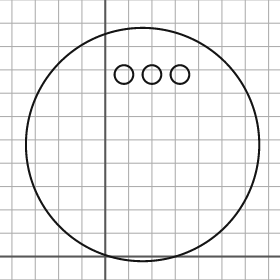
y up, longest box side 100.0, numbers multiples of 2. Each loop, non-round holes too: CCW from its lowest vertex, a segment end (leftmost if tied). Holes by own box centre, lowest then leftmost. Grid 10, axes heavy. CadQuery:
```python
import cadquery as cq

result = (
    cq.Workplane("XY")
    .moveTo(16.0, 48.0)
    .circle(50.0)
    .moveTo(8.0, 78.0)
    .circle(4.0)
    .moveTo(20.0, 78.0)
    .circle(4.0)
    .moveTo(32.0, 78.0)
    .circle(4.0)
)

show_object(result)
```